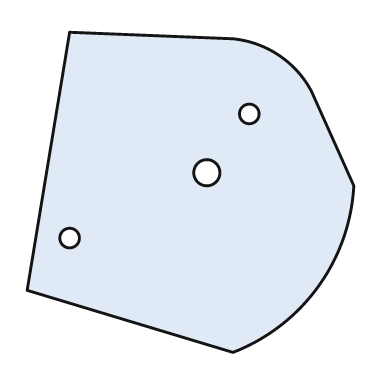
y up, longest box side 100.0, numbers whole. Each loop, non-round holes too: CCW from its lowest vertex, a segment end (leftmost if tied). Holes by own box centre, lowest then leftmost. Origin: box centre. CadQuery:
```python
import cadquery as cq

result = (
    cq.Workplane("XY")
    .moveTo(13.0, -49.0)
    .threePointArc((39.0, -29.0), (50.0, 2.0))
    .lineTo(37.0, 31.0)
    .threePointArc((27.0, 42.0), (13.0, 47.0))
    .lineTo(-37.0, 49.0)
    .lineTo(-50.0, -30.0)
    .close()
    .moveTo(-37.0, -14.0)
    .circle(3.0)
    .moveTo(5.0, 6.0)
    .circle(4.0)
    .moveTo(18.0, 24.0)
    .circle(3.0)
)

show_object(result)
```